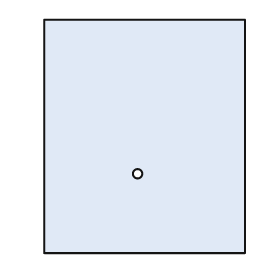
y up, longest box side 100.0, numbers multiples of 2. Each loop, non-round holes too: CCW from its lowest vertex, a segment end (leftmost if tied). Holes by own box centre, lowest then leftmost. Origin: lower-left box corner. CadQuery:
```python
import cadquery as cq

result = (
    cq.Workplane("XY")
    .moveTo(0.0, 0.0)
    .lineTo(86.0, 0.0)
    .lineTo(86.0, 100.0)
    .lineTo(0.0, 100.0)
    .close()
    .moveTo(40.0, 34.0)
    .circle(2.0)
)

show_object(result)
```